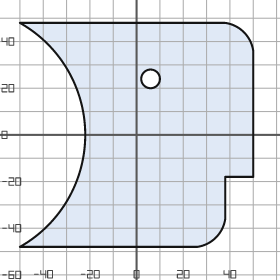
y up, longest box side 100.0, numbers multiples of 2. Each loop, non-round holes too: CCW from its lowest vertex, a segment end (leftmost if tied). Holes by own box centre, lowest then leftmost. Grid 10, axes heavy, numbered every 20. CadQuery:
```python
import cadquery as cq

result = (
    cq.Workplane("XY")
    .moveTo(-50.0, -48.0)
    .lineTo(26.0, -48.0)
    .threePointArc((34.0, -44.0), (38.0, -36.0))
    .lineTo(38.0, -18.0)
    .lineTo(50.0, -18.0)
    .lineTo(50.0, 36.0)
    .threePointArc((46.0, 44.0), (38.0, 48.0))
    .lineTo(-50.0, 48.0)
    .threePointArc((-22.0, 0.0), (-50.0, -48.0))
    .close()
    .moveTo(6.0, 24.0)
    .circle(4.0)
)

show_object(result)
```